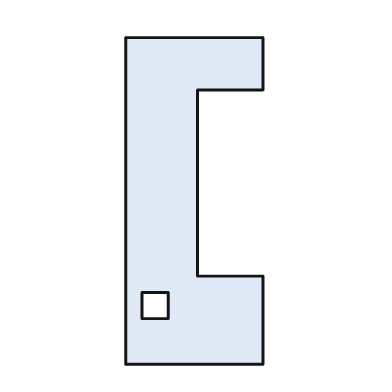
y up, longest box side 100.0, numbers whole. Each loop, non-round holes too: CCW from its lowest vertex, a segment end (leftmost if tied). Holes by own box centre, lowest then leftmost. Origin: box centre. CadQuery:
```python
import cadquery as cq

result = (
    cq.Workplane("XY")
    .moveTo(-21.0, -50.0)
    .lineTo(21.0, -50.0)
    .lineTo(21.0, -23.0)
    .lineTo(1.0, -23.0)
    .lineTo(1.0, 34.0)
    .lineTo(21.0, 34.0)
    .lineTo(21.0, 50.0)
    .lineTo(-21.0, 50.0)
    .close()
    .moveTo(-16.0, -36.0)
    .lineTo(-8.0, -36.0)
    .lineTo(-8.0, -28.0)
    .lineTo(-16.0, -28.0)
    .close()
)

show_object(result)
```